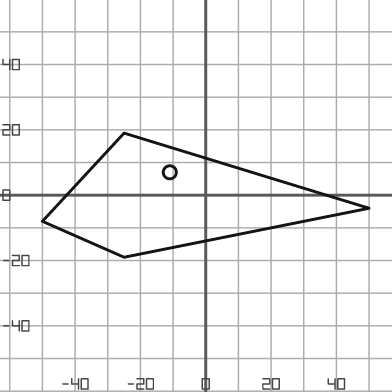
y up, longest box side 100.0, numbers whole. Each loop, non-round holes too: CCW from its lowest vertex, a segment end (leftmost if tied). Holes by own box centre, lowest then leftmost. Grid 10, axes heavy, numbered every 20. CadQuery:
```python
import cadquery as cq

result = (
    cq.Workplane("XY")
    .moveTo(-25.0, -19.0)
    .lineTo(50.0, -4.0)
    .lineTo(-25.0, 19.0)
    .lineTo(-50.0, -8.0)
    .close()
    .moveTo(-11.0, 7.0)
    .circle(2.0)
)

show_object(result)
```